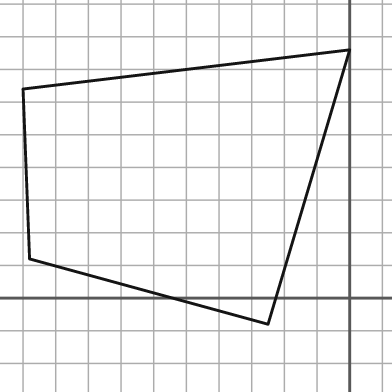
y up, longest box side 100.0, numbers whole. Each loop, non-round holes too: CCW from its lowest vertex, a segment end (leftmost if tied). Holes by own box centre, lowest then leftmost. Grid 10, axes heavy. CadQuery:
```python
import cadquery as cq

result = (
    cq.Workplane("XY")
    .moveTo(-25.0, -8.0)
    .lineTo(0.0, 76.0)
    .lineTo(-100.0, 64.0)
    .lineTo(-98.0, 12.0)
    .close()
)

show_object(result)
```